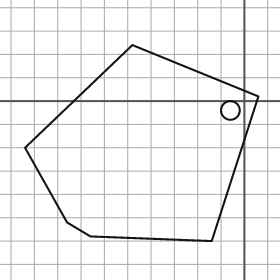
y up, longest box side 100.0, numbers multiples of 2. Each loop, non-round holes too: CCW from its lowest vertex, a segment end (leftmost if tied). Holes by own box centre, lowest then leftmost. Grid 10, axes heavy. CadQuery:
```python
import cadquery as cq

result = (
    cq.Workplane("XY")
    .moveTo(-14.0, -60.0)
    .lineTo(6.0, 2.0)
    .lineTo(-48.0, 24.0)
    .lineTo(-94.0, -20.0)
    .lineTo(-76.0, -52.0)
    .lineTo(-66.0, -58.0)
    .close()
    .moveTo(-6.0, -4.0)
    .circle(4.0)
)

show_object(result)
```